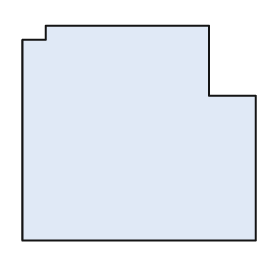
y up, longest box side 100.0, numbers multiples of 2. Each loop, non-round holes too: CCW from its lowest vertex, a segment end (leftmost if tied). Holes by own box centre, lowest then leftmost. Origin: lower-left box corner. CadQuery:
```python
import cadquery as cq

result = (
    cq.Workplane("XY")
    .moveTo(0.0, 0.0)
    .lineTo(100.0, 0.0)
    .lineTo(100.0, 62.0)
    .lineTo(80.0, 62.0)
    .lineTo(80.0, 92.0)
    .lineTo(10.0, 92.0)
    .lineTo(10.0, 86.0)
    .lineTo(0.0, 86.0)
    .close()
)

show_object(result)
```